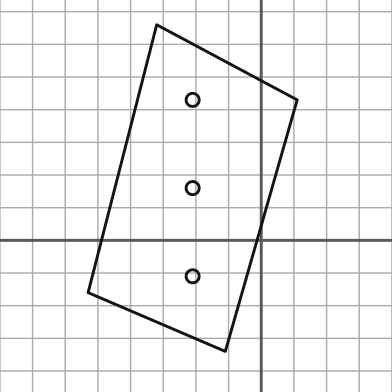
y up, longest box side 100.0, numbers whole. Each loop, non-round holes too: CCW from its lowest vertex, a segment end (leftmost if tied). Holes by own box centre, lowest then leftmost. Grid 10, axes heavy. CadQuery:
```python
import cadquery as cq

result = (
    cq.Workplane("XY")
    .moveTo(-11.0, -34.0)
    .lineTo(11.0, 43.0)
    .lineTo(-32.0, 66.0)
    .lineTo(-53.0, -16.0)
    .close()
    .moveTo(-21.0, -11.0)
    .circle(2.0)
    .moveTo(-21.0, 16.0)
    .circle(2.0)
    .moveTo(-21.0, 43.0)
    .circle(2.0)
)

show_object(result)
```